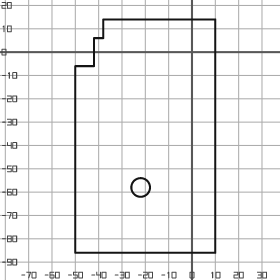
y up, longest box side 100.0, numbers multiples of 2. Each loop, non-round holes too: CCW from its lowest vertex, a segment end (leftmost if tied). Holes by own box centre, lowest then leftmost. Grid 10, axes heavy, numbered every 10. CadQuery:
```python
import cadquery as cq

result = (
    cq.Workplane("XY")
    .moveTo(-50.0, -86.0)
    .lineTo(10.0, -86.0)
    .lineTo(10.0, 14.0)
    .lineTo(-38.0, 14.0)
    .lineTo(-38.0, 6.0)
    .lineTo(-42.0, 6.0)
    .lineTo(-42.0, -6.0)
    .lineTo(-50.0, -6.0)
    .close()
    .moveTo(-22.0, -58.0)
    .circle(4.0)
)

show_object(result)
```